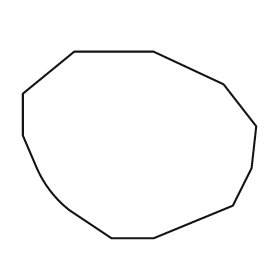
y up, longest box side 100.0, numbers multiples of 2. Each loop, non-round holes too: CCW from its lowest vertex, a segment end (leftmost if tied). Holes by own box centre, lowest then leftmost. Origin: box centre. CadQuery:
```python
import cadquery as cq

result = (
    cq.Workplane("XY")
    .moveTo(-12.0, -40.0)
    .lineTo(6.0, -40.0)
    .lineTo(40.0, -26.0)
    .lineTo(48.0, -10.0)
    .lineTo(50.0, 8.0)
    .lineTo(36.0, 26.0)
    .lineTo(6.0, 40.0)
    .lineTo(-28.0, 40.0)
    .lineTo(-50.0, 22.0)
    .lineTo(-50.0, 4.0)
    .lineTo(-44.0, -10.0)
    .threePointArc((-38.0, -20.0), (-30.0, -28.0))
    .close()
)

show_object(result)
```